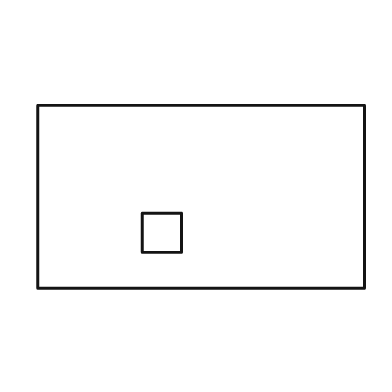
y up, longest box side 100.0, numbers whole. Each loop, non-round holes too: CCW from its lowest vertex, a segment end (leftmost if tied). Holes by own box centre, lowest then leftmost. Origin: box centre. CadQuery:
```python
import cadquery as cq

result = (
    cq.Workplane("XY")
    .moveTo(-50.0, -28.0)
    .lineTo(50.0, -28.0)
    .lineTo(50.0, 28.0)
    .lineTo(-50.0, 28.0)
    .close()
    .moveTo(-18.0, -17.0)
    .lineTo(-6.0, -17.0)
    .lineTo(-6.0, -5.0)
    .lineTo(-18.0, -5.0)
    .close()
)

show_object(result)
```